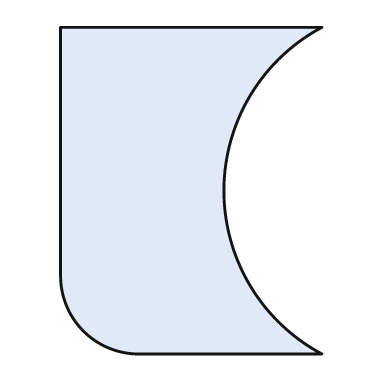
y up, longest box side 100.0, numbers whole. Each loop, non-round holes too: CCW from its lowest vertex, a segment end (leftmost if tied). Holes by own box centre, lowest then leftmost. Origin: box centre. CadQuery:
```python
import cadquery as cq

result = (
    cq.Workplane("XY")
    .moveTo(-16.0, -50.0)
    .lineTo(40.0, -50.0)
    .threePointArc((10.0, 0.0), (40.0, 50.0))
    .lineTo(-40.0, 50.0)
    .lineTo(-40.0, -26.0)
    .threePointArc((-33.0, -43.0), (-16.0, -50.0))
    .close()
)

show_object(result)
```